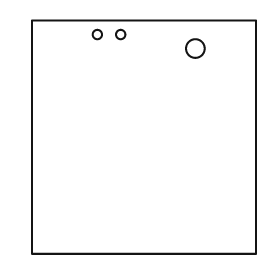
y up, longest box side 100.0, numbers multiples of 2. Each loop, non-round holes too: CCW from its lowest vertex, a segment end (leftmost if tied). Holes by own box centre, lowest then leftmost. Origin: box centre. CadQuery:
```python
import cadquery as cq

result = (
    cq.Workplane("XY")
    .moveTo(-48.0, -50.0)
    .lineTo(48.0, -50.0)
    .lineTo(48.0, 50.0)
    .lineTo(-48.0, 50.0)
    .close()
    .moveTo(22.0, 38.0)
    .circle(4.0)
    .moveTo(-20.0, 44.0)
    .circle(2.0)
    .moveTo(-10.0, 44.0)
    .circle(2.0)
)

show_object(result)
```